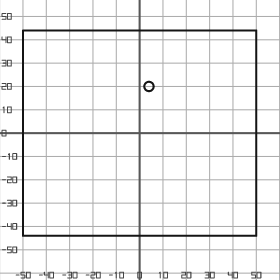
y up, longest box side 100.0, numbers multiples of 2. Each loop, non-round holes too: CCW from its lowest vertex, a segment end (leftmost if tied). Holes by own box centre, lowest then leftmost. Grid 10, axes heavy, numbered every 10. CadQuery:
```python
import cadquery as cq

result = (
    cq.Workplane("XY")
    .moveTo(-50.0, -44.0)
    .lineTo(50.0, -44.0)
    .lineTo(50.0, 44.0)
    .lineTo(-50.0, 44.0)
    .close()
    .moveTo(4.0, 20.0)
    .circle(2.0)
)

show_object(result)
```